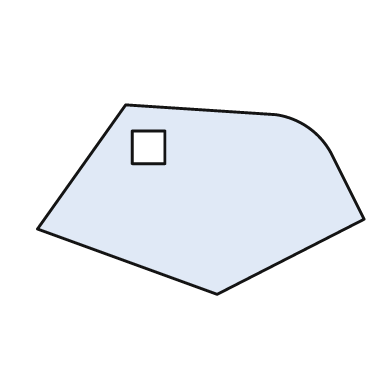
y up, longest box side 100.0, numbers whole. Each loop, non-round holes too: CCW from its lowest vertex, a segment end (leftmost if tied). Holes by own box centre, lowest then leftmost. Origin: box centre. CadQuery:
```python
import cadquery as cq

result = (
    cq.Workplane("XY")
    .moveTo(5.0, -29.0)
    .lineTo(50.0, -6.0)
    .lineTo(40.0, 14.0)
    .threePointArc((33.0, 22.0), (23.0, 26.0))
    .lineTo(-23.0, 29.0)
    .lineTo(-50.0, -9.0)
    .close()
    .moveTo(-21.0, 11.0)
    .lineTo(-11.0, 11.0)
    .lineTo(-11.0, 21.0)
    .lineTo(-21.0, 21.0)
    .close()
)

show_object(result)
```